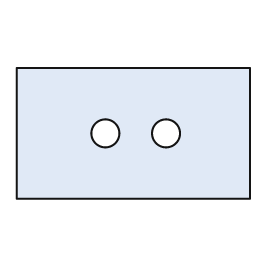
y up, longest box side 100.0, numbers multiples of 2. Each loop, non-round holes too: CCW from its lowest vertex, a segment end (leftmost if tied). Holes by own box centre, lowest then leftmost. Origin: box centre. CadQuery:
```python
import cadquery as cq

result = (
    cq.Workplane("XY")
    .moveTo(-50.0, -28.0)
    .lineTo(50.0, -28.0)
    .lineTo(50.0, 28.0)
    .lineTo(-50.0, 28.0)
    .close()
    .moveTo(-12.0, 0.0)
    .circle(6.0)
    .moveTo(14.0, 0.0)
    .circle(6.0)
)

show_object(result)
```